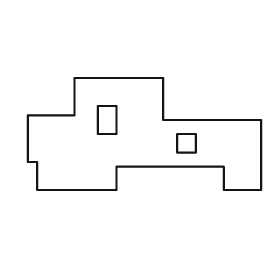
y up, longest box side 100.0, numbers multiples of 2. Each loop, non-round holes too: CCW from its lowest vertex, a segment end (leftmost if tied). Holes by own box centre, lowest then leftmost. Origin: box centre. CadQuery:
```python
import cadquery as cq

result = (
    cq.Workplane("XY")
    .moveTo(-46.0, -24.0)
    .lineTo(-12.0, -24.0)
    .lineTo(-12.0, -14.0)
    .lineTo(34.0, -14.0)
    .lineTo(34.0, -24.0)
    .lineTo(50.0, -24.0)
    .lineTo(50.0, 6.0)
    .lineTo(8.0, 6.0)
    .lineTo(8.0, 24.0)
    .lineTo(-30.0, 24.0)
    .lineTo(-30.0, 8.0)
    .lineTo(-50.0, 8.0)
    .lineTo(-50.0, -12.0)
    .lineTo(-46.0, -12.0)
    .close()
    .moveTo(14.0, -8.0)
    .lineTo(22.0, -8.0)
    .lineTo(22.0, 0.0)
    .lineTo(14.0, 0.0)
    .close()
    .moveTo(-20.0, 0.0)
    .lineTo(-12.0, 0.0)
    .lineTo(-12.0, 12.0)
    .lineTo(-20.0, 12.0)
    .close()
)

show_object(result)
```